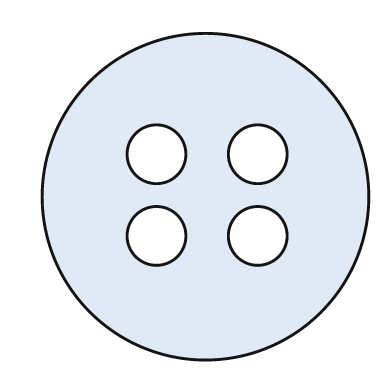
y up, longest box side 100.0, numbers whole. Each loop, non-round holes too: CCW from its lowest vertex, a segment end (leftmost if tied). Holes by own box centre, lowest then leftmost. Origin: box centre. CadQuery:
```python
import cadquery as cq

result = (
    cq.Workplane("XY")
    .moveTo(0.0, 0.0)
    .circle(50.0)
    .moveTo(-15.0, -12.0)
    .circle(9.0)
    .moveTo(16.0, -12.0)
    .circle(9.0)
    .moveTo(-15.0, 13.0)
    .circle(9.0)
    .moveTo(16.0, 13.0)
    .circle(9.0)
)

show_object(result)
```